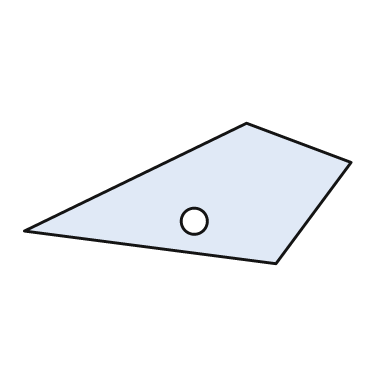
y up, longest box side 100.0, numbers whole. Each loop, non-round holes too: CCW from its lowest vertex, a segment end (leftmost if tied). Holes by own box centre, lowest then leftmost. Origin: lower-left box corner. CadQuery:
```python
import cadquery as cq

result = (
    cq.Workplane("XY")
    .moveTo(77.0, 0.0)
    .lineTo(100.0, 31.0)
    .lineTo(68.0, 43.0)
    .lineTo(0.0, 10.0)
    .close()
    .moveTo(52.0, 13.0)
    .circle(4.0)
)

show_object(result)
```